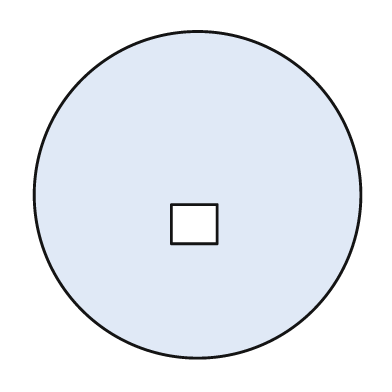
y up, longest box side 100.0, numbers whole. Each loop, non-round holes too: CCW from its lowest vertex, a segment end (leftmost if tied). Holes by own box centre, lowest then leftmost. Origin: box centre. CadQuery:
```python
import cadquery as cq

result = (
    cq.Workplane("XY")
    .moveTo(0.0, 0.0)
    .circle(50.0)
    .moveTo(-8.0, -15.0)
    .lineTo(6.0, -15.0)
    .lineTo(6.0, -3.0)
    .lineTo(-8.0, -3.0)
    .close()
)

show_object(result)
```